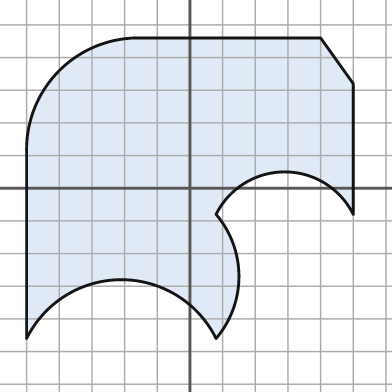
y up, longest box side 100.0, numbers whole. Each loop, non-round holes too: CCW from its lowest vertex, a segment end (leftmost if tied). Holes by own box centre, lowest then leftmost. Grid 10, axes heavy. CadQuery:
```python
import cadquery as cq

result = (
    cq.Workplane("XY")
    .moveTo(-50.0, -46.0)
    .threePointArc((-21.0, -28.0), (8.0, -46.0))
    .threePointArc((15.0, -27.0), (8.0, -8.0))
    .threePointArc((29.0, 5.0), (50.0, -8.0))
    .lineTo(50.0, 32.0)
    .lineTo(40.0, 46.0)
    .lineTo(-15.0, 46.0)
    .threePointArc((-40.0, 36.0), (-50.0, 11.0))
    .close()
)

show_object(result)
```